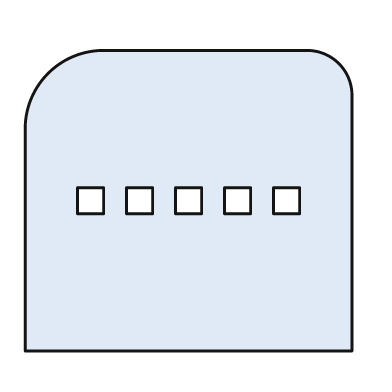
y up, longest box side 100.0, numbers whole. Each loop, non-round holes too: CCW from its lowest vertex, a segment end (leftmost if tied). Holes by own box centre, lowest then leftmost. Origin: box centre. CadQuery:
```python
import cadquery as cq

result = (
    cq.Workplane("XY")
    .moveTo(-50.0, -46.0)
    .lineTo(50.0, -46.0)
    .lineTo(50.0, 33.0)
    .threePointArc((46.0, 42.0), (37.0, 46.0))
    .lineTo(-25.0, 46.0)
    .threePointArc((-43.0, 39.0), (-50.0, 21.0))
    .close()
    .moveTo(-34.0, -4.0)
    .lineTo(-26.0, -4.0)
    .lineTo(-26.0, 4.0)
    .lineTo(-34.0, 4.0)
    .close()
    .moveTo(-19.0, -4.0)
    .lineTo(-11.0, -4.0)
    .lineTo(-11.0, 4.0)
    .lineTo(-19.0, 4.0)
    .close()
    .moveTo(-4.0, -4.0)
    .lineTo(4.0, -4.0)
    .lineTo(4.0, 4.0)
    .lineTo(-4.0, 4.0)
    .close()
    .moveTo(11.0, -4.0)
    .lineTo(19.0, -4.0)
    .lineTo(19.0, 4.0)
    .lineTo(11.0, 4.0)
    .close()
    .moveTo(26.0, -4.0)
    .lineTo(34.0, -4.0)
    .lineTo(34.0, 4.0)
    .lineTo(26.0, 4.0)
    .close()
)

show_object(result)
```